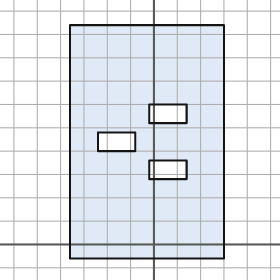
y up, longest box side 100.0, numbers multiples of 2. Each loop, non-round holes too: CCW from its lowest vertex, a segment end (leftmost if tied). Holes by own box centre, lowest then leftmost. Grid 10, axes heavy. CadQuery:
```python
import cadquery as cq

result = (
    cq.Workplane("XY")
    .moveTo(-36.0, -6.0)
    .lineTo(30.0, -6.0)
    .lineTo(30.0, 94.0)
    .lineTo(-36.0, 94.0)
    .close()
    .moveTo(-2.0, 28.0)
    .lineTo(14.0, 28.0)
    .lineTo(14.0, 36.0)
    .lineTo(-2.0, 36.0)
    .close()
    .moveTo(-24.0, 40.0)
    .lineTo(-8.0, 40.0)
    .lineTo(-8.0, 48.0)
    .lineTo(-24.0, 48.0)
    .close()
    .moveTo(-2.0, 52.0)
    .lineTo(14.0, 52.0)
    .lineTo(14.0, 60.0)
    .lineTo(-2.0, 60.0)
    .close()
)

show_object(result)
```